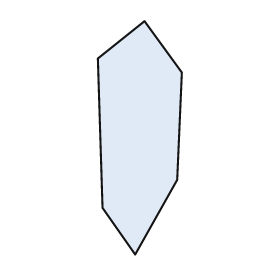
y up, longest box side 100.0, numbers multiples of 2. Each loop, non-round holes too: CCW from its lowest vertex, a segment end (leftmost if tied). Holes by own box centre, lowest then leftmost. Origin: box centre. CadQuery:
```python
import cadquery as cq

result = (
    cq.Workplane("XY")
    .moveTo(-2.0, -50.0)
    .lineTo(16.0, -18.0)
    .lineTo(18.0, 28.0)
    .lineTo(2.0, 50.0)
    .lineTo(-18.0, 34.0)
    .lineTo(-16.0, -30.0)
    .close()
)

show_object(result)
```